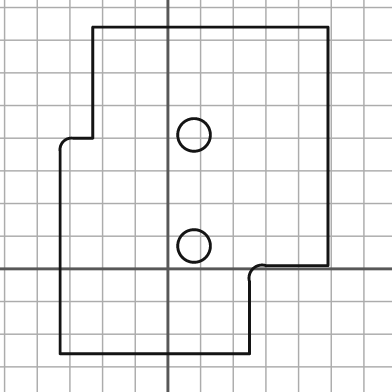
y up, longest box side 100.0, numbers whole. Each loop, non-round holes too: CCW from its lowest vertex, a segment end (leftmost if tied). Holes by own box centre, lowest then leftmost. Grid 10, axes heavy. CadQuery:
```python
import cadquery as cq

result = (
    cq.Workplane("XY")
    .moveTo(-33.0, -26.0)
    .lineTo(25.0, -26.0)
    .lineTo(25.0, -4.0)
    .threePointArc((26.0, 0.0), (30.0, 1.0))
    .lineTo(49.0, 1.0)
    .lineTo(49.0, 74.0)
    .lineTo(-23.0, 74.0)
    .lineTo(-23.0, 40.0)
    .lineTo(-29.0, 40.0)
    .threePointArc((-32.0, 39.0), (-33.0, 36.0))
    .close()
    .moveTo(8.0, 7.0)
    .circle(5.0)
    .moveTo(8.0, 41.0)
    .circle(5.0)
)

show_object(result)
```